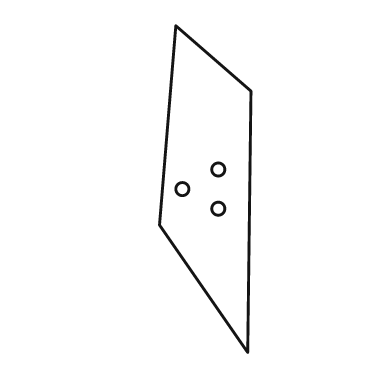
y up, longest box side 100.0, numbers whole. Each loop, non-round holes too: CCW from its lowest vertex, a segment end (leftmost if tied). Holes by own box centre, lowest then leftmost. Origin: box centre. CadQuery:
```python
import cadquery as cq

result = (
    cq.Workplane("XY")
    .moveTo(13.0, -50.0)
    .lineTo(14.0, 30.0)
    .lineTo(-9.0, 50.0)
    .lineTo(-14.0, -11.0)
    .close()
    .moveTo(4.0, -6.0)
    .circle(2.0)
    .moveTo(-7.0, 0.0)
    .circle(2.0)
    .moveTo(4.0, 6.0)
    .circle(2.0)
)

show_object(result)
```